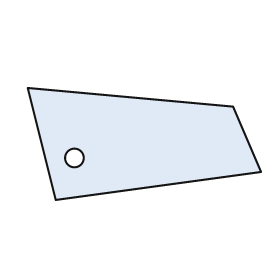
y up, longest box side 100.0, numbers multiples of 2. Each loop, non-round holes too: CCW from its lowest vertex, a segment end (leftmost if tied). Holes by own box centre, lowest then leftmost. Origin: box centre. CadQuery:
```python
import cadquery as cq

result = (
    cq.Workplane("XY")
    .moveTo(-38.0, -24.0)
    .lineTo(50.0, -12.0)
    .lineTo(38.0, 16.0)
    .lineTo(-50.0, 24.0)
    .close()
    .moveTo(-30.0, -6.0)
    .circle(4.0)
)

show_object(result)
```